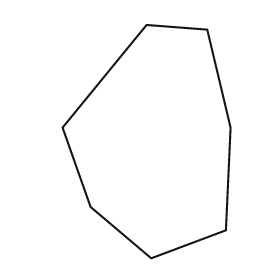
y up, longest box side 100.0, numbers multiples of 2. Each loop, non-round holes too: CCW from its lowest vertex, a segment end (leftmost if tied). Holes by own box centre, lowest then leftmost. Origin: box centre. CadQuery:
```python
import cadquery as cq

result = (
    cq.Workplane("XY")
    .moveTo(2.0, -50.0)
    .lineTo(34.0, -38.0)
    .lineTo(36.0, 6.0)
    .lineTo(26.0, 48.0)
    .lineTo(0.0, 50.0)
    .lineTo(-36.0, 6.0)
    .lineTo(-24.0, -28.0)
    .close()
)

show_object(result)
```